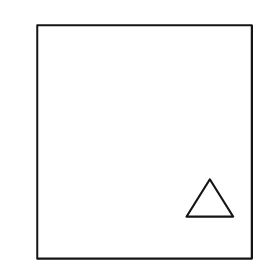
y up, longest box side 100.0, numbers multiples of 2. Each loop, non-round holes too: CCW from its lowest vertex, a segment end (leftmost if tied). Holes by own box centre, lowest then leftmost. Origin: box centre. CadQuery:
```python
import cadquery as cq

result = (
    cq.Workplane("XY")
    .moveTo(-46.0, -50.0)
    .lineTo(46.0, -50.0)
    .lineTo(46.0, 50.0)
    .lineTo(-46.0, 50.0)
    .close()
    .moveTo(18.0, -32.0)
    .lineTo(38.0, -32.0)
    .lineTo(28.0, -16.0)
    .close()
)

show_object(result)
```